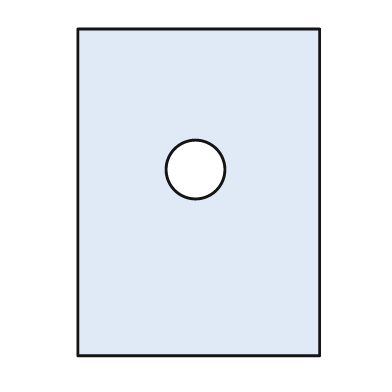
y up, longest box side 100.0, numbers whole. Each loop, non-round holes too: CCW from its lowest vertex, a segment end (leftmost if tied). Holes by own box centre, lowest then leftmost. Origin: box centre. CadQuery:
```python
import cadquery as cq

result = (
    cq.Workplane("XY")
    .moveTo(-37.0, -50.0)
    .lineTo(37.0, -50.0)
    .lineTo(37.0, 50.0)
    .lineTo(-37.0, 50.0)
    .close()
    .moveTo(-1.0, 7.0)
    .circle(9.0)
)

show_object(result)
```